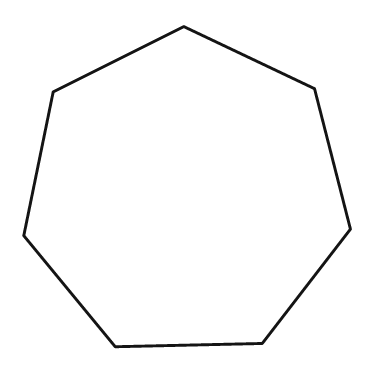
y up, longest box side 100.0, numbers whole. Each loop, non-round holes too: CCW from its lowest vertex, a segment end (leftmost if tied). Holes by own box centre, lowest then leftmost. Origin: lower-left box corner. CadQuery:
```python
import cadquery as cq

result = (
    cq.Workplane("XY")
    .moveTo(28.0, 0.0)
    .lineTo(73.0, 1.0)
    .lineTo(100.0, 36.0)
    .lineTo(89.0, 79.0)
    .lineTo(49.0, 98.0)
    .lineTo(9.0, 78.0)
    .lineTo(0.0, 34.0)
    .close()
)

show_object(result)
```